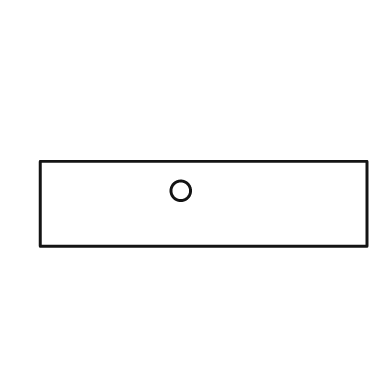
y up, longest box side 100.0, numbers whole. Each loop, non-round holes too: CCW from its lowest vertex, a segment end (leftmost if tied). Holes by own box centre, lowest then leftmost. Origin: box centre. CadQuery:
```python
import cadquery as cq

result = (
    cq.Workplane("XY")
    .moveTo(-50.0, -13.0)
    .lineTo(50.0, -13.0)
    .lineTo(50.0, 13.0)
    .lineTo(-50.0, 13.0)
    .close()
    .moveTo(-7.0, 4.0)
    .circle(3.0)
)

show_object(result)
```